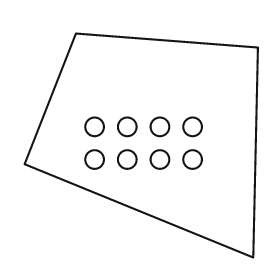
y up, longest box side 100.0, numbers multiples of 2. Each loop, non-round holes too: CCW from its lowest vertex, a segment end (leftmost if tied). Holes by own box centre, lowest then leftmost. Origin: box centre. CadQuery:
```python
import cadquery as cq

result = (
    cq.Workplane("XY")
    .moveTo(48.0, -48.0)
    .lineTo(50.0, 42.0)
    .lineTo(-28.0, 48.0)
    .lineTo(-50.0, -8.0)
    .close()
    .moveTo(-20.0, -6.0)
    .circle(4.0)
    .moveTo(-6.0, -6.0)
    .circle(4.0)
    .moveTo(8.0, -6.0)
    .circle(4.0)
    .moveTo(22.0, -6.0)
    .circle(4.0)
    .moveTo(-20.0, 8.0)
    .circle(4.0)
    .moveTo(-6.0, 8.0)
    .circle(4.0)
    .moveTo(8.0, 8.0)
    .circle(4.0)
    .moveTo(22.0, 8.0)
    .circle(4.0)
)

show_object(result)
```